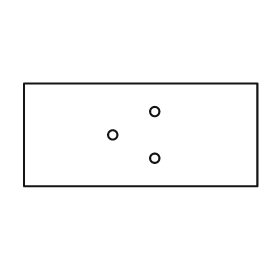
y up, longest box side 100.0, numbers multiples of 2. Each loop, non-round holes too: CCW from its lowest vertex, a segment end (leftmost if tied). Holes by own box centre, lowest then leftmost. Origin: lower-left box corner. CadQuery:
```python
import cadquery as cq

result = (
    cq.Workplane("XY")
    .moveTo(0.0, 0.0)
    .lineTo(100.0, 0.0)
    .lineTo(100.0, 44.0)
    .lineTo(0.0, 44.0)
    .close()
    .moveTo(56.0, 12.0)
    .circle(2.0)
    .moveTo(38.0, 22.0)
    .circle(2.0)
    .moveTo(56.0, 32.0)
    .circle(2.0)
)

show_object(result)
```